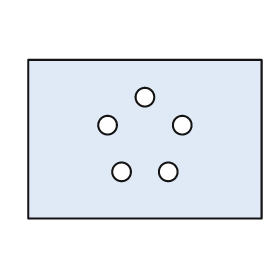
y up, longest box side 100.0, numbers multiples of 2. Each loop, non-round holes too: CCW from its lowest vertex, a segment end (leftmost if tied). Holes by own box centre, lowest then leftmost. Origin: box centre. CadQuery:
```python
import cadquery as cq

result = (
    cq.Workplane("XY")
    .moveTo(-50.0, -34.0)
    .lineTo(50.0, -34.0)
    .lineTo(50.0, 34.0)
    .lineTo(-50.0, 34.0)
    .close()
    .moveTo(-10.0, -14.0)
    .circle(4.0)
    .moveTo(10.0, -14.0)
    .circle(4.0)
    .moveTo(-16.0, 6.0)
    .circle(4.0)
    .moveTo(16.0, 6.0)
    .circle(4.0)
    .moveTo(0.0, 18.0)
    .circle(4.0)
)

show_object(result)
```